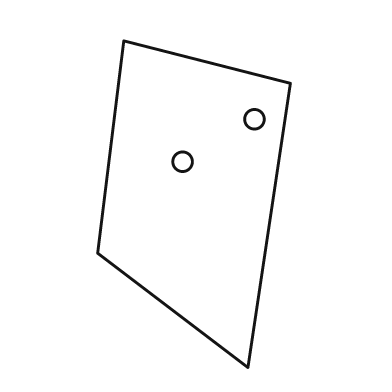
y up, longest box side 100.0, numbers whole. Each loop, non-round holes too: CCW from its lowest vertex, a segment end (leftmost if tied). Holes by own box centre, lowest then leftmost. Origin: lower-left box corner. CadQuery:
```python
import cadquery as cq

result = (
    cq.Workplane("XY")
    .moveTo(46.0, 0.0)
    .lineTo(59.0, 87.0)
    .lineTo(8.0, 100.0)
    .lineTo(0.0, 35.0)
    .close()
    .moveTo(26.0, 63.0)
    .circle(3.0)
    .moveTo(48.0, 76.0)
    .circle(3.0)
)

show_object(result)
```